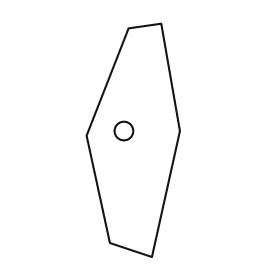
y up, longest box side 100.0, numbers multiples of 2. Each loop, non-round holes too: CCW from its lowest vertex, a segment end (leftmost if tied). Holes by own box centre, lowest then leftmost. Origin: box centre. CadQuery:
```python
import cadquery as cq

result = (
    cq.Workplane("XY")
    .moveTo(8.0, -50.0)
    .lineTo(20.0, 4.0)
    .lineTo(12.0, 50.0)
    .lineTo(-2.0, 48.0)
    .lineTo(-20.0, 2.0)
    .lineTo(-10.0, -44.0)
    .close()
    .moveTo(-4.0, 4.0)
    .circle(4.0)
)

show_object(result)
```